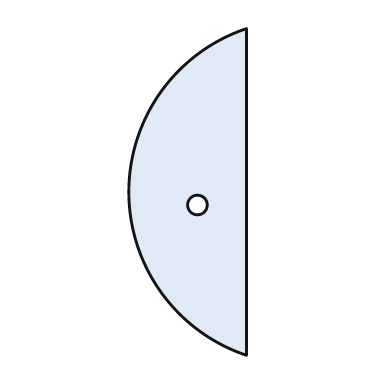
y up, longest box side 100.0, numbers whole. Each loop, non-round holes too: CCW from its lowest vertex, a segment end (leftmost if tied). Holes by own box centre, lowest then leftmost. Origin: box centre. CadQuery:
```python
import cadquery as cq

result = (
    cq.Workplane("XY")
    .moveTo(18.0, -50.0)
    .lineTo(18.0, 50.0)
    .threePointArc((-18.0, 0.0), (18.0, -50.0))
    .close()
    .moveTo(3.0, -4.0)
    .circle(3.0)
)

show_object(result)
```